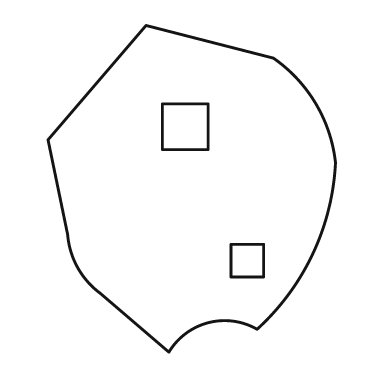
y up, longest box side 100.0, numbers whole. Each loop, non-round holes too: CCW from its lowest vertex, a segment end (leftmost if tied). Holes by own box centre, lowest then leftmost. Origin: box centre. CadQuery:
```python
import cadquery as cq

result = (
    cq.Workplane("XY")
    .moveTo(-7.0, -50.0)
    .threePointArc((5.0, -41.0), (20.0, -43.0))
    .threePointArc((37.0, -20.0), (44.0, 8.0))
    .threePointArc((38.0, 26.0), (25.0, 40.0))
    .lineTo(-14.0, 50.0)
    .lineTo(-44.0, 15.0)
    .lineTo(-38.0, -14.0)
    .threePointArc((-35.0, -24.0), (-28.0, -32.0))
    .close()
    .moveTo(12.0, -27.0)
    .lineTo(22.0, -27.0)
    .lineTo(22.0, -17.0)
    .lineTo(12.0, -17.0)
    .close()
    .moveTo(-9.0, 12.0)
    .lineTo(5.0, 12.0)
    .lineTo(5.0, 26.0)
    .lineTo(-9.0, 26.0)
    .close()
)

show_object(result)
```